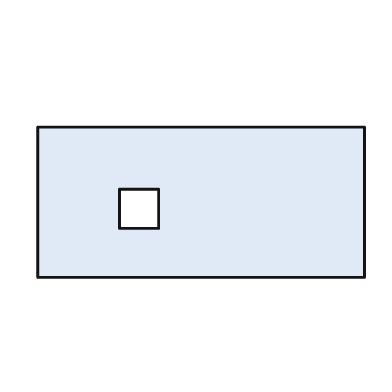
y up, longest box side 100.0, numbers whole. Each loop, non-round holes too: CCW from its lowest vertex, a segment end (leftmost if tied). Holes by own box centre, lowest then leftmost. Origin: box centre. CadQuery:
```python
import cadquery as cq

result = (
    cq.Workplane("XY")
    .moveTo(-50.0, -23.0)
    .lineTo(50.0, -23.0)
    .lineTo(50.0, 23.0)
    .lineTo(-50.0, 23.0)
    .close()
    .moveTo(-25.0, -8.0)
    .lineTo(-13.0, -8.0)
    .lineTo(-13.0, 4.0)
    .lineTo(-25.0, 4.0)
    .close()
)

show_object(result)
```